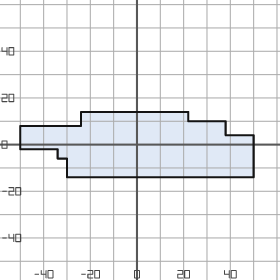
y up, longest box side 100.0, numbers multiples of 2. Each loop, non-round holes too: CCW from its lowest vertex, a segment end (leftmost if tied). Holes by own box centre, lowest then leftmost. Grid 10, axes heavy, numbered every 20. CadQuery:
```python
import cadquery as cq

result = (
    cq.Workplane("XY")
    .moveTo(-30.0, -14.0)
    .lineTo(50.0, -14.0)
    .lineTo(50.0, 4.0)
    .lineTo(38.0, 4.0)
    .lineTo(38.0, 10.0)
    .lineTo(22.0, 10.0)
    .lineTo(22.0, 14.0)
    .lineTo(-24.0, 14.0)
    .lineTo(-24.0, 8.0)
    .lineTo(-50.0, 8.0)
    .lineTo(-50.0, -2.0)
    .lineTo(-34.0, -2.0)
    .lineTo(-34.0, -6.0)
    .lineTo(-30.0, -6.0)
    .close()
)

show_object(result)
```